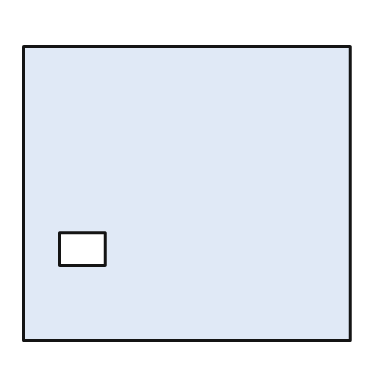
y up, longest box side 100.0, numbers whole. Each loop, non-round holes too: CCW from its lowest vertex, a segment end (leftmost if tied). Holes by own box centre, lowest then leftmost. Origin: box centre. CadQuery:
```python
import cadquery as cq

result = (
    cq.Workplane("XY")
    .moveTo(-50.0, -45.0)
    .lineTo(50.0, -45.0)
    .lineTo(50.0, 45.0)
    .lineTo(-50.0, 45.0)
    .close()
    .moveTo(-39.0, -22.0)
    .lineTo(-25.0, -22.0)
    .lineTo(-25.0, -12.0)
    .lineTo(-39.0, -12.0)
    .close()
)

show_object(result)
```